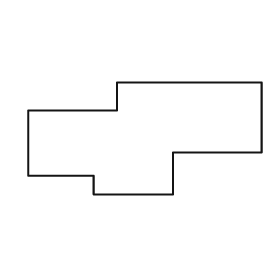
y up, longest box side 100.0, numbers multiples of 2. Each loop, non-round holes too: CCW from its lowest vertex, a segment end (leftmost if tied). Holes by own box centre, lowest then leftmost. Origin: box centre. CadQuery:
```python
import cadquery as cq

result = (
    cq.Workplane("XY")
    .moveTo(-22.0, -24.0)
    .lineTo(12.0, -24.0)
    .lineTo(12.0, -6.0)
    .lineTo(50.0, -6.0)
    .lineTo(50.0, 24.0)
    .lineTo(-12.0, 24.0)
    .lineTo(-12.0, 12.0)
    .lineTo(-50.0, 12.0)
    .lineTo(-50.0, -16.0)
    .lineTo(-22.0, -16.0)
    .close()
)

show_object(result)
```